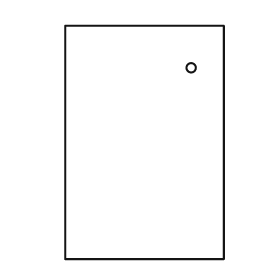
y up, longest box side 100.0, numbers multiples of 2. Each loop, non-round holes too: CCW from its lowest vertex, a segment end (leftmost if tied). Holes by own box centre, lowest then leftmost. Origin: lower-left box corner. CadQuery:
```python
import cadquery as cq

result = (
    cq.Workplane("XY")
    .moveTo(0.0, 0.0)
    .lineTo(68.0, 0.0)
    .lineTo(68.0, 100.0)
    .lineTo(0.0, 100.0)
    .close()
    .moveTo(54.0, 82.0)
    .circle(2.0)
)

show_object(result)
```